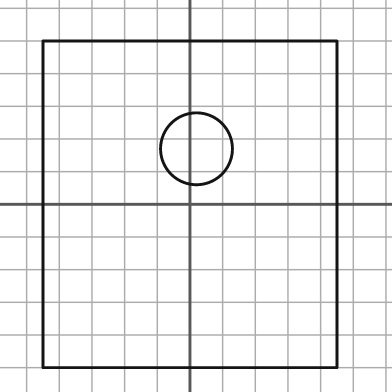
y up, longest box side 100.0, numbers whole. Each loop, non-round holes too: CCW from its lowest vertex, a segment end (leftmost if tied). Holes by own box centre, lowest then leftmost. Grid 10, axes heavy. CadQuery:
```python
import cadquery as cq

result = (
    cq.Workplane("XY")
    .moveTo(-45.0, -50.0)
    .lineTo(45.0, -50.0)
    .lineTo(45.0, 50.0)
    .lineTo(-45.0, 50.0)
    .close()
    .moveTo(2.0, 17.0)
    .circle(11.0)
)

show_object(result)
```